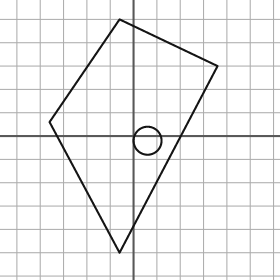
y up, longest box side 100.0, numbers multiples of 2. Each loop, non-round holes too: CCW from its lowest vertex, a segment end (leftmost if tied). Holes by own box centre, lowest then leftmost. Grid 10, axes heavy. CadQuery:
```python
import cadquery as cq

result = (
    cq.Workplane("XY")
    .moveTo(-6.0, -50.0)
    .lineTo(36.0, 30.0)
    .lineTo(-6.0, 50.0)
    .lineTo(-36.0, 6.0)
    .close()
    .moveTo(6.0, -2.0)
    .circle(6.0)
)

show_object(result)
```